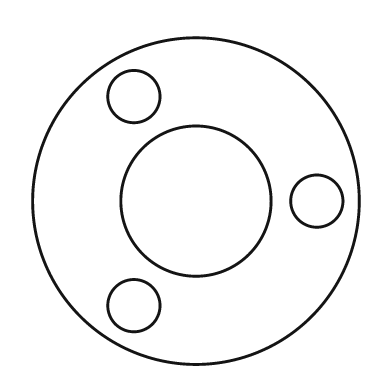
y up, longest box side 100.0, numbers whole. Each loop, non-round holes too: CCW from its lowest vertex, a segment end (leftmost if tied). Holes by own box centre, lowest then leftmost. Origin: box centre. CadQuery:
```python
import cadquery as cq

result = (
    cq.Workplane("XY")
    .moveTo(0.0, 0.0)
    .circle(50.0)
    .moveTo(-19.0, -32.0)
    .circle(8.0)
    .moveTo(0.0, 0.0)
    .circle(23.0)
    .moveTo(37.0, 0.0)
    .circle(8.0)
    .moveTo(-19.0, 32.0)
    .circle(8.0)
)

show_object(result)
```